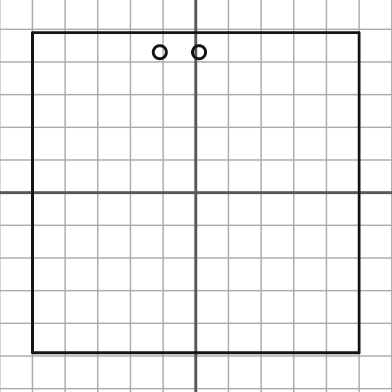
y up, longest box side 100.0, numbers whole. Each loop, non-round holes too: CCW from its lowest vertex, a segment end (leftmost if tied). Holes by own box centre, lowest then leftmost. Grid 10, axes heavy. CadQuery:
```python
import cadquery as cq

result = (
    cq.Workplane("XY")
    .moveTo(-50.0, -49.0)
    .lineTo(50.0, -49.0)
    .lineTo(50.0, 49.0)
    .lineTo(-50.0, 49.0)
    .close()
    .moveTo(-11.0, 43.0)
    .circle(2.0)
    .moveTo(1.0, 43.0)
    .circle(2.0)
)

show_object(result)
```